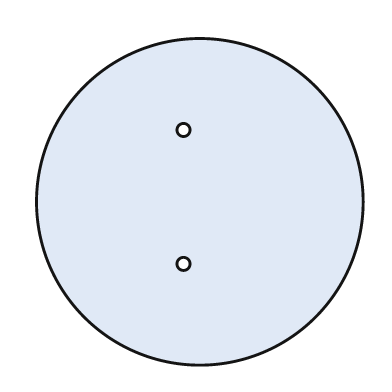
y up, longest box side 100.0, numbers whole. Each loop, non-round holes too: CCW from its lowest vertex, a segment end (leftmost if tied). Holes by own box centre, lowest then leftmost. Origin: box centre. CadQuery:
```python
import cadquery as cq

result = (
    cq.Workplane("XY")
    .moveTo(0.0, 0.0)
    .circle(50.0)
    .moveTo(-5.0, -19.0)
    .circle(2.0)
    .moveTo(-5.0, 22.0)
    .circle(2.0)
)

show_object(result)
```